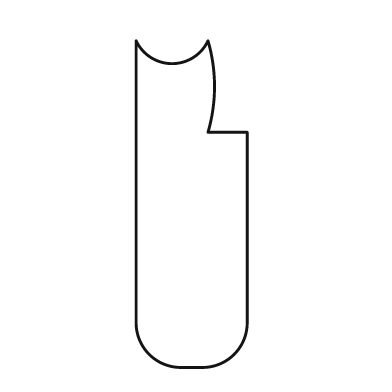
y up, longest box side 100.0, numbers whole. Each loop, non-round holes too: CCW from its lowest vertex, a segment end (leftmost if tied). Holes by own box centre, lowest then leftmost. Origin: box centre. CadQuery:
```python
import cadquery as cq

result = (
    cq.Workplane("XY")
    .moveTo(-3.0, -50.0)
    .lineTo(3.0, -50.0)
    .threePointArc((13.0, -46.0), (17.0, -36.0))
    .lineTo(17.0, 22.0)
    .lineTo(5.0, 22.0)
    .threePointArc((7.0, 36.0), (5.0, 50.0))
    .threePointArc((-6.0, 43.0), (-17.0, 50.0))
    .lineTo(-17.0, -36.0)
    .threePointArc((-13.0, -46.0), (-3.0, -50.0))
    .close()
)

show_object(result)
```